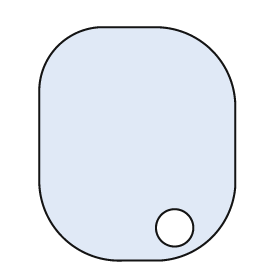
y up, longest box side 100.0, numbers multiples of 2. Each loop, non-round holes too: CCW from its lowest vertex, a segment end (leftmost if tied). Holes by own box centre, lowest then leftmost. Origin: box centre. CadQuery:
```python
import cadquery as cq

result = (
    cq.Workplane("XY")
    .moveTo(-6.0, -50.0)
    .lineTo(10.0, -50.0)
    .threePointArc((32.0, -40.0), (42.0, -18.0))
    .lineTo(42.0, 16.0)
    .threePointArc((32.0, 40.0), (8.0, 50.0))
    .lineTo(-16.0, 50.0)
    .threePointArc((-34.0, 42.0), (-42.0, 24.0))
    .lineTo(-42.0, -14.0)
    .threePointArc((-32.0, -40.0), (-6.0, -50.0))
    .close()
    .moveTo(16.0, -36.0)
    .circle(8.0)
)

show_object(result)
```